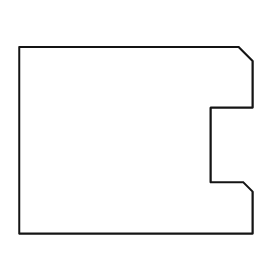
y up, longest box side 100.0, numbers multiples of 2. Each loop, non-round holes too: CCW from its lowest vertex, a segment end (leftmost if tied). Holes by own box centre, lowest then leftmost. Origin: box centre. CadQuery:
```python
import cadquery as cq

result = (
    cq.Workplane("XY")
    .moveTo(-50.0, -40.0)
    .lineTo(50.0, -40.0)
    .lineTo(50.0, -22.0)
    .lineTo(46.0, -18.0)
    .lineTo(32.0, -18.0)
    .lineTo(32.0, 14.0)
    .lineTo(50.0, 14.0)
    .lineTo(50.0, 34.0)
    .lineTo(44.0, 40.0)
    .lineTo(-50.0, 40.0)
    .close()
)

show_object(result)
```